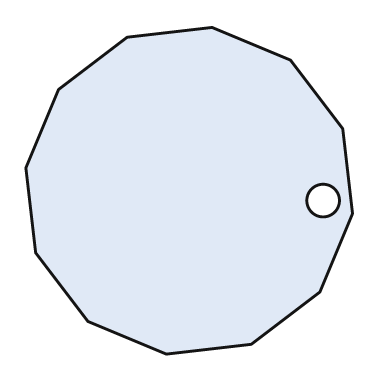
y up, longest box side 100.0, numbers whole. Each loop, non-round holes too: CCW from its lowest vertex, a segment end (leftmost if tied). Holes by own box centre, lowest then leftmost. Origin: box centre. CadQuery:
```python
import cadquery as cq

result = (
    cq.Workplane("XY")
    .moveTo(-7.0, -50.0)
    .lineTo(19.0, -47.0)
    .lineTo(40.0, -31.0)
    .lineTo(50.0, -7.0)
    .lineTo(47.0, 19.0)
    .lineTo(31.0, 40.0)
    .lineTo(7.0, 50.0)
    .lineTo(-19.0, 47.0)
    .lineTo(-40.0, 31.0)
    .lineTo(-50.0, 7.0)
    .lineTo(-47.0, -19.0)
    .lineTo(-31.0, -40.0)
    .close()
    .moveTo(41.0, -3.0)
    .circle(5.0)
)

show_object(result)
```